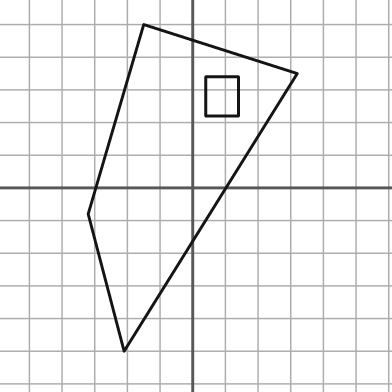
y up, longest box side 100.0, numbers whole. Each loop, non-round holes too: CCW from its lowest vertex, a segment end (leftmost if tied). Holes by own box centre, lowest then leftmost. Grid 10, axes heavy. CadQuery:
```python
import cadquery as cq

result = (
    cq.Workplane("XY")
    .moveTo(-21.0, -50.0)
    .lineTo(32.0, 35.0)
    .lineTo(-15.0, 50.0)
    .lineTo(-32.0, -8.0)
    .close()
    .moveTo(4.0, 22.0)
    .lineTo(14.0, 22.0)
    .lineTo(14.0, 34.0)
    .lineTo(4.0, 34.0)
    .close()
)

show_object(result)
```